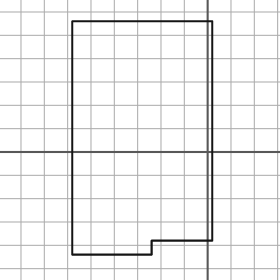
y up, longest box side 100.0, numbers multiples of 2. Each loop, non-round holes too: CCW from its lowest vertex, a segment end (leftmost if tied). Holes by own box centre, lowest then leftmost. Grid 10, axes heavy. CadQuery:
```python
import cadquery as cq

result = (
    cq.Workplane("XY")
    .moveTo(-58.0, -44.0)
    .lineTo(-24.0, -44.0)
    .lineTo(-24.0, -38.0)
    .lineTo(2.0, -38.0)
    .lineTo(2.0, 56.0)
    .lineTo(-58.0, 56.0)
    .close()
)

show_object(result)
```